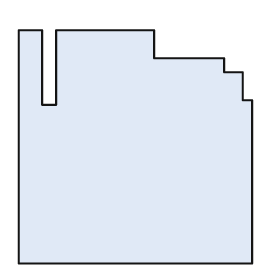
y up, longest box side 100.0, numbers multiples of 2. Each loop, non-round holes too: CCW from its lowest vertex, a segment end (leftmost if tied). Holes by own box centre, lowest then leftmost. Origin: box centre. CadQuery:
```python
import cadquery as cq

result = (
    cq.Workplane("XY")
    .moveTo(-50.0, -50.0)
    .lineTo(50.0, -50.0)
    .lineTo(50.0, 20.0)
    .lineTo(46.0, 20.0)
    .lineTo(46.0, 32.0)
    .lineTo(38.0, 32.0)
    .lineTo(38.0, 38.0)
    .lineTo(8.0, 38.0)
    .lineTo(8.0, 50.0)
    .lineTo(-34.0, 50.0)
    .lineTo(-34.0, 18.0)
    .lineTo(-40.0, 18.0)
    .lineTo(-40.0, 50.0)
    .lineTo(-50.0, 50.0)
    .close()
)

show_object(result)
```